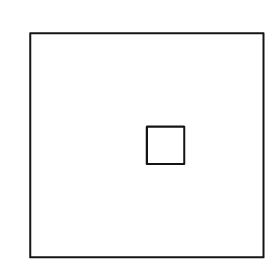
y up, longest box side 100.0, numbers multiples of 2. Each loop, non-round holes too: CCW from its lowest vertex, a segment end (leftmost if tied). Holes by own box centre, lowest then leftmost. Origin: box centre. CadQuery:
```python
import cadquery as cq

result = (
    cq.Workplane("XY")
    .moveTo(-50.0, -48.0)
    .lineTo(50.0, -48.0)
    .lineTo(50.0, 48.0)
    .lineTo(-50.0, 48.0)
    .close()
    .moveTo(0.0, -8.0)
    .lineTo(16.0, -8.0)
    .lineTo(16.0, 8.0)
    .lineTo(0.0, 8.0)
    .close()
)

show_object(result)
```